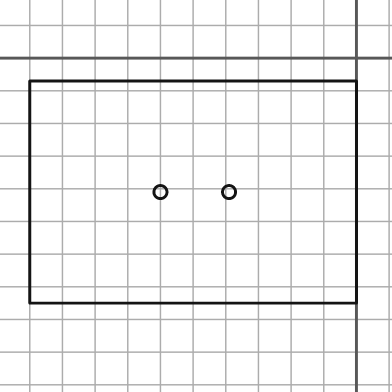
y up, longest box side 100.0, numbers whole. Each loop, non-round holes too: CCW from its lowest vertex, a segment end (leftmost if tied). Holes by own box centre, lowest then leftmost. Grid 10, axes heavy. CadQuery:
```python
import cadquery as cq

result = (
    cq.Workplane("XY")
    .moveTo(-100.0, -75.0)
    .lineTo(0.0, -75.0)
    .lineTo(0.0, -7.0)
    .lineTo(-100.0, -7.0)
    .close()
    .moveTo(-60.0, -41.0)
    .circle(2.0)
    .moveTo(-39.0, -41.0)
    .circle(2.0)
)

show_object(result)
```